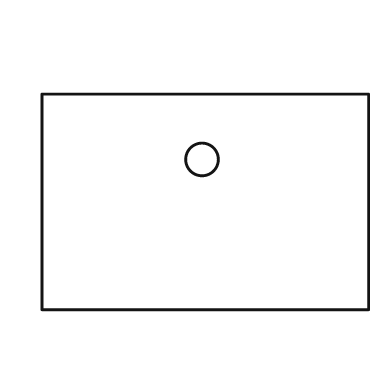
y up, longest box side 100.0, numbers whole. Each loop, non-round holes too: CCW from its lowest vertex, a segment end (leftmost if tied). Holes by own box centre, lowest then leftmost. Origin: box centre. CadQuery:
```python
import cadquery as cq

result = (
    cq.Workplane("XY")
    .moveTo(-50.0, -33.0)
    .lineTo(50.0, -33.0)
    .lineTo(50.0, 33.0)
    .lineTo(-50.0, 33.0)
    .close()
    .moveTo(-1.0, 13.0)
    .circle(5.0)
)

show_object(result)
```